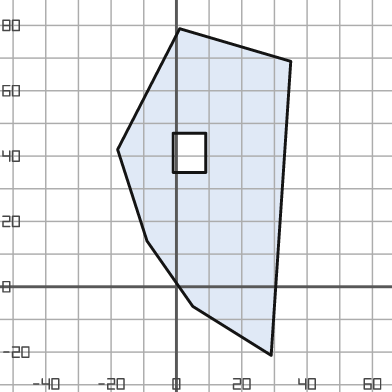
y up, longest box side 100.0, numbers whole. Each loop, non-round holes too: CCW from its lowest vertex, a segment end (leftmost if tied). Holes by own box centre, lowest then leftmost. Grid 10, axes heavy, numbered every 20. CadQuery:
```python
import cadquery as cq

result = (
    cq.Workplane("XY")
    .moveTo(29.0, -21.0)
    .lineTo(35.0, 69.0)
    .lineTo(1.0, 79.0)
    .lineTo(-18.0, 42.0)
    .lineTo(-9.0, 14.0)
    .lineTo(5.0, -6.0)
    .close()
    .moveTo(-1.0, 35.0)
    .lineTo(9.0, 35.0)
    .lineTo(9.0, 47.0)
    .lineTo(-1.0, 47.0)
    .close()
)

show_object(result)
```